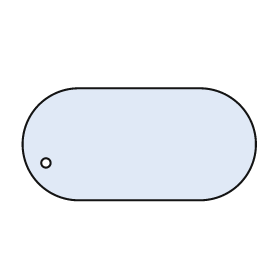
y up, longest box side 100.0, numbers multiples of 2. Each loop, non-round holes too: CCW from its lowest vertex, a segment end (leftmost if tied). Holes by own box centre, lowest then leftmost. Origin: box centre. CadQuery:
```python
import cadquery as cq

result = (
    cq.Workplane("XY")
    .moveTo(-26.0, -24.0)
    .lineTo(26.0, -24.0)
    .threePointArc((50.0, 0.0), (26.0, 24.0))
    .lineTo(-26.0, 24.0)
    .threePointArc((-50.0, 0.0), (-26.0, -24.0))
    .close()
    .moveTo(-40.0, -8.0)
    .circle(2.0)
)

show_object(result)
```